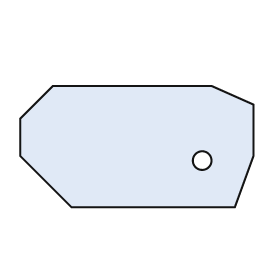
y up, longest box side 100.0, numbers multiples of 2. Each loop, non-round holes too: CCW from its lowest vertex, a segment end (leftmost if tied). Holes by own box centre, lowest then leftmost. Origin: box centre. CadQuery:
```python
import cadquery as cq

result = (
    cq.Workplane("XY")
    .moveTo(-28.0, -26.0)
    .lineTo(42.0, -26.0)
    .lineTo(50.0, -4.0)
    .lineTo(50.0, 18.0)
    .lineTo(32.0, 26.0)
    .lineTo(-36.0, 26.0)
    .lineTo(-50.0, 12.0)
    .lineTo(-50.0, -4.0)
    .close()
    .moveTo(28.0, -6.0)
    .circle(4.0)
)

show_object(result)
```